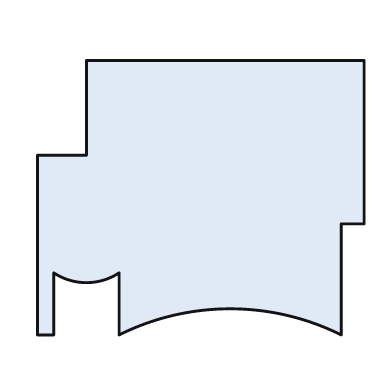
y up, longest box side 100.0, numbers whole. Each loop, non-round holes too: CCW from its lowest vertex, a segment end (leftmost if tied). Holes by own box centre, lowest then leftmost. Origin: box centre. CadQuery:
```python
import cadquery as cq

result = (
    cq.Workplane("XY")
    .moveTo(-50.0, -42.0)
    .lineTo(-45.0, -42.0)
    .lineTo(-45.0, -23.0)
    .threePointArc((-35.0, -26.0), (-25.0, -23.0))
    .lineTo(-25.0, -42.0)
    .threePointArc((9.0, -34.0), (43.0, -42.0))
    .lineTo(43.0, -8.0)
    .lineTo(50.0, -8.0)
    .lineTo(50.0, 42.0)
    .lineTo(-35.0, 42.0)
    .lineTo(-35.0, 13.0)
    .lineTo(-50.0, 13.0)
    .close()
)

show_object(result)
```